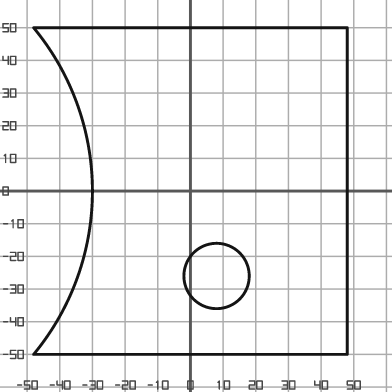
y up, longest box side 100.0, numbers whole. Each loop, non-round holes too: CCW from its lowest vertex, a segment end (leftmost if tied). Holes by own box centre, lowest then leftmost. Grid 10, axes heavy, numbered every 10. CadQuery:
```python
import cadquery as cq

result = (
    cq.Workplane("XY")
    .moveTo(-48.0, -50.0)
    .lineTo(48.0, -50.0)
    .lineTo(48.0, 50.0)
    .lineTo(-48.0, 50.0)
    .threePointArc((-30.0, 0.0), (-48.0, -50.0))
    .close()
    .moveTo(8.0, -26.0)
    .circle(10.0)
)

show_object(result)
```